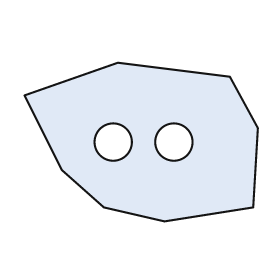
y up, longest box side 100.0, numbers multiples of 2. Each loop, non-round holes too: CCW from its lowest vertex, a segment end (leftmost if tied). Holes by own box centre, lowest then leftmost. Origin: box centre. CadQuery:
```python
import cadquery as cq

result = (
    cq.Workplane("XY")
    .moveTo(10.0, -34.0)
    .lineTo(48.0, -28.0)
    .lineTo(50.0, 6.0)
    .lineTo(38.0, 28.0)
    .lineTo(-10.0, 34.0)
    .lineTo(-50.0, 20.0)
    .lineTo(-34.0, -12.0)
    .lineTo(-16.0, -28.0)
    .close()
    .moveTo(-12.0, 0.0)
    .circle(8.0)
    .moveTo(14.0, 0.0)
    .circle(8.0)
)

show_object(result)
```